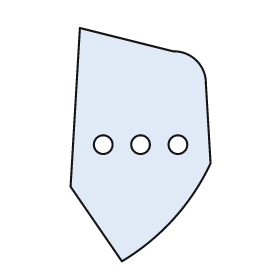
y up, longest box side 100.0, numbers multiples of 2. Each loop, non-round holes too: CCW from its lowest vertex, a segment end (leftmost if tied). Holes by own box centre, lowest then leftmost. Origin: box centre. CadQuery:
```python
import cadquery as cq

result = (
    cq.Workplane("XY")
    .moveTo(-8.0, -50.0)
    .threePointArc((14.0, -32.0), (30.0, -8.0))
    .lineTo(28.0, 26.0)
    .threePointArc((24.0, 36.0), (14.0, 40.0))
    .lineTo(-26.0, 50.0)
    .lineTo(-30.0, -18.0)
    .close()
    .moveTo(-16.0, 0.0)
    .circle(4.0)
    .moveTo(0.0, 0.0)
    .circle(4.0)
    .moveTo(16.0, 0.0)
    .circle(4.0)
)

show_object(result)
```